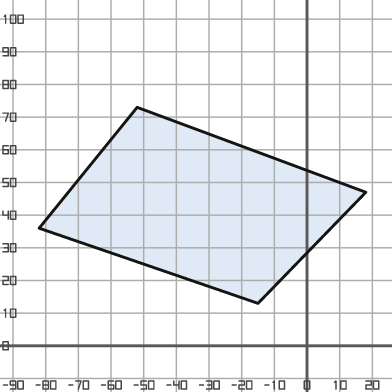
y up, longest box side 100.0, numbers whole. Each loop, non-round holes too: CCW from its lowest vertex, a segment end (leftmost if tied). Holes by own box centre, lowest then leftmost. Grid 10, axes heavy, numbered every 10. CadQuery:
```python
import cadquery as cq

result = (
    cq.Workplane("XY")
    .moveTo(-15.0, 13.0)
    .lineTo(18.0, 47.0)
    .lineTo(-52.0, 73.0)
    .lineTo(-82.0, 36.0)
    .close()
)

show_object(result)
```